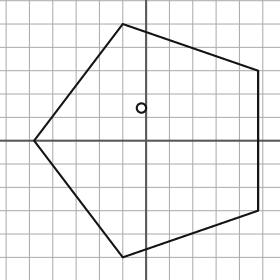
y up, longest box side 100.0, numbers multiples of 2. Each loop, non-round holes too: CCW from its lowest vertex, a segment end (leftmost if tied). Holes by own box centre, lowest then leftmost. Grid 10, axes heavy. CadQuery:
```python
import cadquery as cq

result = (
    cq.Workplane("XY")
    .moveTo(-10.0, -50.0)
    .lineTo(48.0, -30.0)
    .lineTo(48.0, 30.0)
    .lineTo(-10.0, 50.0)
    .lineTo(-48.0, 0.0)
    .close()
    .moveTo(-2.0, 14.0)
    .circle(2.0)
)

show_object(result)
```